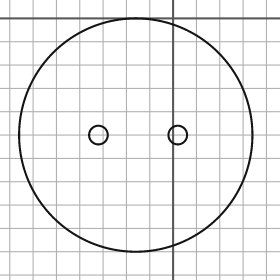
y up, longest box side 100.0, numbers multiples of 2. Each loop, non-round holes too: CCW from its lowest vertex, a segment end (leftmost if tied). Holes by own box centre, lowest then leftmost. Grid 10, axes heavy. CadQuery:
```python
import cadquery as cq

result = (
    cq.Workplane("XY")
    .moveTo(-16.0, -50.0)
    .circle(50.0)
    .moveTo(-32.0, -50.0)
    .circle(4.0)
    .moveTo(2.0, -50.0)
    .circle(4.0)
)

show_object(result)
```